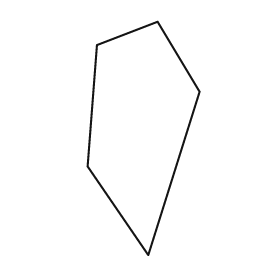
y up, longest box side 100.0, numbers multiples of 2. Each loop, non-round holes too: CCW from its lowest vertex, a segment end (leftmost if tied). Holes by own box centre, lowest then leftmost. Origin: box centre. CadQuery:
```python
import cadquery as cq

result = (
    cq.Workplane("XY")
    .moveTo(2.0, -50.0)
    .lineTo(24.0, 20.0)
    .lineTo(6.0, 50.0)
    .lineTo(-20.0, 40.0)
    .lineTo(-24.0, -12.0)
    .close()
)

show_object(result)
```